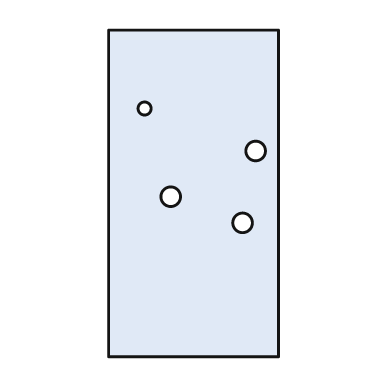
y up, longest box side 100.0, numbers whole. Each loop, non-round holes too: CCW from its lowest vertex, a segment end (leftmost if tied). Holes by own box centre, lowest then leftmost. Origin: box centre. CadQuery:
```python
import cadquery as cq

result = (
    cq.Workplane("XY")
    .moveTo(-26.0, -50.0)
    .lineTo(26.0, -50.0)
    .lineTo(26.0, 50.0)
    .lineTo(-26.0, 50.0)
    .close()
    .moveTo(15.0, -9.0)
    .circle(3.0)
    .moveTo(-7.0, -1.0)
    .circle(3.0)
    .moveTo(19.0, 13.0)
    .circle(3.0)
    .moveTo(-15.0, 26.0)
    .circle(2.0)
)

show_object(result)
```